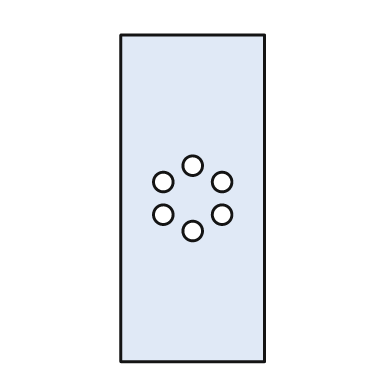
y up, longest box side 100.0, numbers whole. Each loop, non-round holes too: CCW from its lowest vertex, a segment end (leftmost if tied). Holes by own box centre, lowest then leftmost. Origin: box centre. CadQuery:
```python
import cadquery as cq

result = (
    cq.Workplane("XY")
    .moveTo(-22.0, -50.0)
    .lineTo(22.0, -50.0)
    .lineTo(22.0, 50.0)
    .lineTo(-22.0, 50.0)
    .close()
    .moveTo(0.0, -10.0)
    .circle(3.0)
    .moveTo(-9.0, -5.0)
    .circle(3.0)
    .moveTo(9.0, -5.0)
    .circle(3.0)
    .moveTo(-9.0, 5.0)
    .circle(3.0)
    .moveTo(9.0, 5.0)
    .circle(3.0)
    .moveTo(0.0, 10.0)
    .circle(3.0)
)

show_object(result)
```